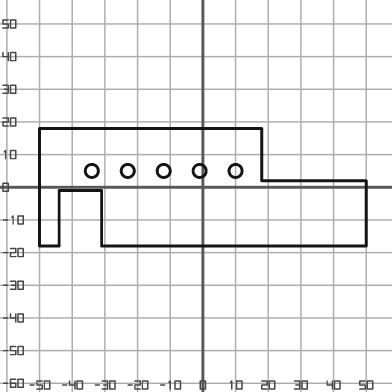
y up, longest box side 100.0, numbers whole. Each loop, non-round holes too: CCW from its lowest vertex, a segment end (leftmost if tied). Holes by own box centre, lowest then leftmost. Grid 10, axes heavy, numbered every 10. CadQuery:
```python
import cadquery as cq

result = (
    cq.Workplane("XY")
    .moveTo(-50.0, -18.0)
    .lineTo(-44.0, -18.0)
    .lineTo(-44.0, -1.0)
    .lineTo(-31.0, -1.0)
    .lineTo(-31.0, -18.0)
    .lineTo(50.0, -18.0)
    .lineTo(50.0, 2.0)
    .lineTo(18.0, 2.0)
    .lineTo(18.0, 18.0)
    .lineTo(-50.0, 18.0)
    .close()
    .moveTo(-34.0, 5.0)
    .circle(2.0)
    .moveTo(-23.0, 5.0)
    .circle(2.0)
    .moveTo(-12.0, 5.0)
    .circle(2.0)
    .moveTo(-1.0, 5.0)
    .circle(2.0)
    .moveTo(10.0, 5.0)
    .circle(2.0)
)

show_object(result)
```